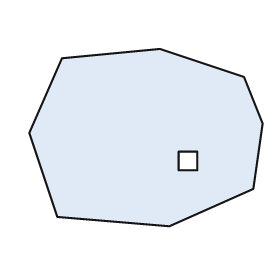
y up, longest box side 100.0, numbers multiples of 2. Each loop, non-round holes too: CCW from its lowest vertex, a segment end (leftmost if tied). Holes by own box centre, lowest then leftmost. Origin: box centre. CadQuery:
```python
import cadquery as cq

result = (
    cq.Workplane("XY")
    .moveTo(10.0, -38.0)
    .lineTo(46.0, -22.0)
    .lineTo(50.0, 6.0)
    .lineTo(42.0, 26.0)
    .lineTo(6.0, 38.0)
    .lineTo(-36.0, 34.0)
    .lineTo(-50.0, 2.0)
    .lineTo(-38.0, -34.0)
    .close()
    .moveTo(14.0, -14.0)
    .lineTo(22.0, -14.0)
    .lineTo(22.0, -6.0)
    .lineTo(14.0, -6.0)
    .close()
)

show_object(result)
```